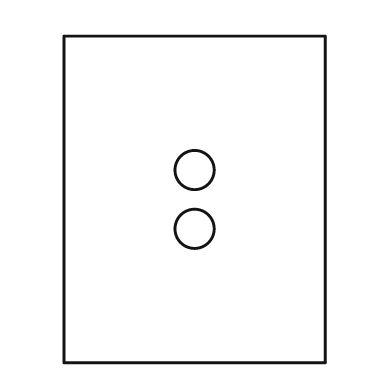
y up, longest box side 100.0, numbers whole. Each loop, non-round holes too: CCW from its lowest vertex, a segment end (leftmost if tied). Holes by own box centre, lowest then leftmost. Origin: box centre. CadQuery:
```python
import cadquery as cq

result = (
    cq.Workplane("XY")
    .moveTo(-40.0, -50.0)
    .lineTo(40.0, -50.0)
    .lineTo(40.0, 50.0)
    .lineTo(-40.0, 50.0)
    .close()
    .moveTo(0.0, -9.0)
    .circle(6.0)
    .moveTo(0.0, 9.0)
    .circle(6.0)
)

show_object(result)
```